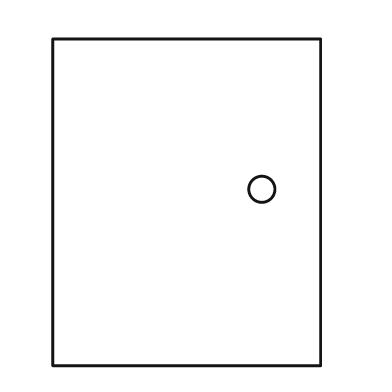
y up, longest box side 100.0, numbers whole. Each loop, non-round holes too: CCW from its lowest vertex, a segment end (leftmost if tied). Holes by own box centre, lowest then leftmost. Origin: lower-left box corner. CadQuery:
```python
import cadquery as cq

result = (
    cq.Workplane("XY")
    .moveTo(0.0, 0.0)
    .lineTo(82.0, 0.0)
    .lineTo(82.0, 100.0)
    .lineTo(0.0, 100.0)
    .close()
    .moveTo(64.0, 54.0)
    .circle(4.0)
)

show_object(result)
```